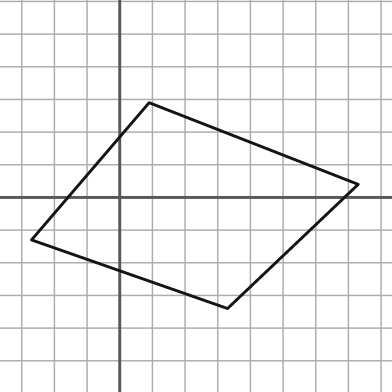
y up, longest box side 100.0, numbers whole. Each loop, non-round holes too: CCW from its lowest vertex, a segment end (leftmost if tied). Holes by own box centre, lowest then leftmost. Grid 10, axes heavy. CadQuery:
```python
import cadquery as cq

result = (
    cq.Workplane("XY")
    .moveTo(33.0, -34.0)
    .lineTo(73.0, 4.0)
    .lineTo(9.0, 29.0)
    .lineTo(-27.0, -13.0)
    .close()
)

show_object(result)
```